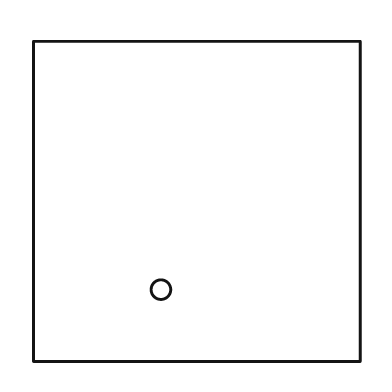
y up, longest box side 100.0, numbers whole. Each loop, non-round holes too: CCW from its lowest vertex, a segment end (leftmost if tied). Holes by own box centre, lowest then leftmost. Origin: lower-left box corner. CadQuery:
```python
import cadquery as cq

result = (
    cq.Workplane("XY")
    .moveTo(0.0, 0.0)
    .lineTo(100.0, 0.0)
    .lineTo(100.0, 98.0)
    .lineTo(0.0, 98.0)
    .close()
    .moveTo(39.0, 22.0)
    .circle(3.0)
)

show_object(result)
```